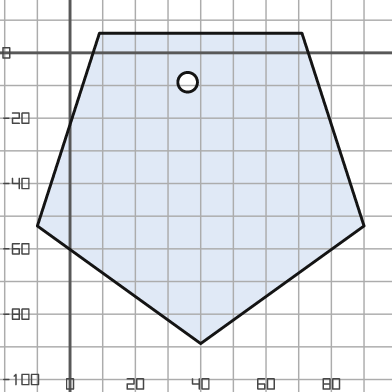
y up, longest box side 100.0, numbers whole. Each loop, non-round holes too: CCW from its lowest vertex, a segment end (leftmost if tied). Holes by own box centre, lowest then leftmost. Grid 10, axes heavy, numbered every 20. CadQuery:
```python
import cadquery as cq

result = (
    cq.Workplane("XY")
    .moveTo(40.0, -89.0)
    .lineTo(90.0, -53.0)
    .lineTo(71.0, 6.0)
    .lineTo(9.0, 6.0)
    .lineTo(-10.0, -53.0)
    .close()
    .moveTo(36.0, -9.0)
    .circle(3.0)
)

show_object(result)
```